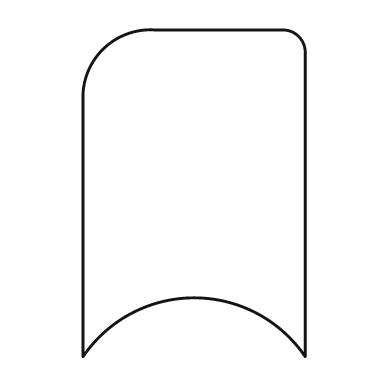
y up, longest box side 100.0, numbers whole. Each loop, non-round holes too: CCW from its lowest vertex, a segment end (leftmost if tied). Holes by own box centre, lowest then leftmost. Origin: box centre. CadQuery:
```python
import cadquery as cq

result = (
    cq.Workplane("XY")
    .moveTo(-34.0, -50.0)
    .threePointArc((0.0, -32.0), (34.0, -50.0))
    .lineTo(34.0, 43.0)
    .threePointArc((32.0, 48.0), (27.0, 50.0))
    .lineTo(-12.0, 50.0)
    .threePointArc((-28.0, 44.0), (-34.0, 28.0))
    .close()
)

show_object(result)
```